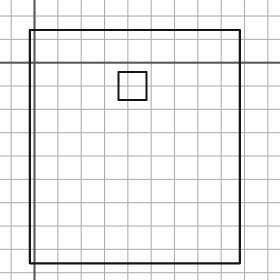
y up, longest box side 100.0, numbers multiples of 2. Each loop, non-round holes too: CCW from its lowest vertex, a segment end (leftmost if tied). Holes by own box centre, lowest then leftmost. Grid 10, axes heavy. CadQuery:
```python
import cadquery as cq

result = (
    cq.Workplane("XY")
    .moveTo(-2.0, -86.0)
    .lineTo(88.0, -86.0)
    .lineTo(88.0, 14.0)
    .lineTo(-2.0, 14.0)
    .close()
    .moveTo(36.0, -16.0)
    .lineTo(48.0, -16.0)
    .lineTo(48.0, -4.0)
    .lineTo(36.0, -4.0)
    .close()
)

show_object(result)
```